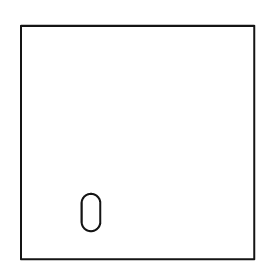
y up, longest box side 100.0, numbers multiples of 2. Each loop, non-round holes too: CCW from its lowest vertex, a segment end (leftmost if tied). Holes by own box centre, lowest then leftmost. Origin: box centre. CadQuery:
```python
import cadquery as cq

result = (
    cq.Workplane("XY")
    .moveTo(-50.0, -50.0)
    .lineTo(50.0, -50.0)
    .lineTo(50.0, 50.0)
    .lineTo(-50.0, 50.0)
    .close()
    .moveTo(-24.0, -34.0)
    .threePointArc((-20.0, -38.0), (-16.0, -34.0))
    .lineTo(-16.0, -26.0)
    .threePointArc((-20.0, -22.0), (-24.0, -26.0))
    .close()
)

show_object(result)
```